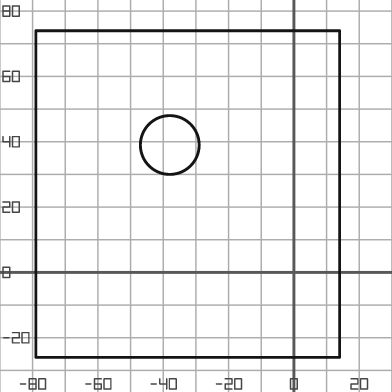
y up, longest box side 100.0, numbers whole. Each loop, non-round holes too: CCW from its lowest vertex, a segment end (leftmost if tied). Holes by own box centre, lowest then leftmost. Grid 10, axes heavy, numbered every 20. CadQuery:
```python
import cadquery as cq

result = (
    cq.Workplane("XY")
    .moveTo(-79.0, -26.0)
    .lineTo(14.0, -26.0)
    .lineTo(14.0, 74.0)
    .lineTo(-79.0, 74.0)
    .close()
    .moveTo(-38.0, 39.0)
    .circle(9.0)
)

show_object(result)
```